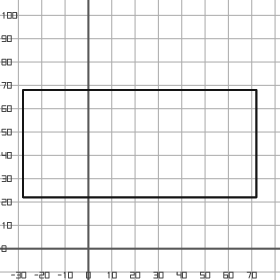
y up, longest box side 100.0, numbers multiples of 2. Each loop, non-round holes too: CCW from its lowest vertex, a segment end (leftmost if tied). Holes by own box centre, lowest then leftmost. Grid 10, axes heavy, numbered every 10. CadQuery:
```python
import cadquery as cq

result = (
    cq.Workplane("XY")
    .moveTo(-28.0, 22.0)
    .lineTo(72.0, 22.0)
    .lineTo(72.0, 68.0)
    .lineTo(-28.0, 68.0)
    .close()
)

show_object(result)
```